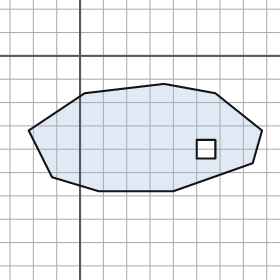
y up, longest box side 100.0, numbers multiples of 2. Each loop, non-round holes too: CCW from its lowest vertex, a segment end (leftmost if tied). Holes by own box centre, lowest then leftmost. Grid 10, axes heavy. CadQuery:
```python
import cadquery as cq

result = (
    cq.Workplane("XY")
    .moveTo(8.0, -58.0)
    .lineTo(40.0, -58.0)
    .lineTo(74.0, -46.0)
    .lineTo(78.0, -32.0)
    .lineTo(58.0, -16.0)
    .lineTo(36.0, -12.0)
    .lineTo(2.0, -16.0)
    .lineTo(-22.0, -32.0)
    .lineTo(-12.0, -52.0)
    .close()
    .moveTo(50.0, -44.0)
    .lineTo(58.0, -44.0)
    .lineTo(58.0, -36.0)
    .lineTo(50.0, -36.0)
    .close()
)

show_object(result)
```